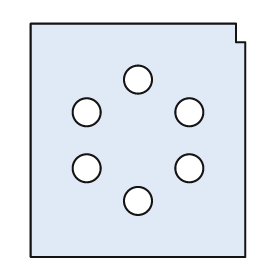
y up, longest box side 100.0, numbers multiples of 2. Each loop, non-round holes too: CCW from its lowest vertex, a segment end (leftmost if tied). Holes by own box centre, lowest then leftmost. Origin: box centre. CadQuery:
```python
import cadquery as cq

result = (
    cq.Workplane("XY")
    .moveTo(-46.0, -50.0)
    .lineTo(46.0, -50.0)
    .lineTo(46.0, 42.0)
    .lineTo(42.0, 42.0)
    .lineTo(42.0, 50.0)
    .lineTo(-46.0, 50.0)
    .close()
    .moveTo(0.0, -26.0)
    .circle(6.0)
    .moveTo(-22.0, -12.0)
    .circle(6.0)
    .moveTo(22.0, -12.0)
    .circle(6.0)
    .moveTo(-22.0, 12.0)
    .circle(6.0)
    .moveTo(22.0, 12.0)
    .circle(6.0)
    .moveTo(0.0, 26.0)
    .circle(6.0)
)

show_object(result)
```